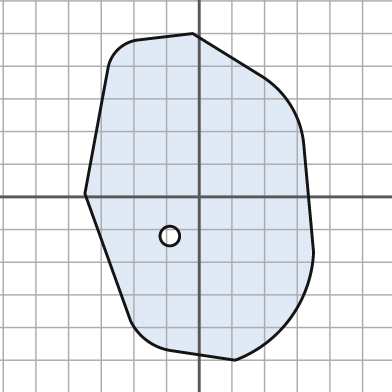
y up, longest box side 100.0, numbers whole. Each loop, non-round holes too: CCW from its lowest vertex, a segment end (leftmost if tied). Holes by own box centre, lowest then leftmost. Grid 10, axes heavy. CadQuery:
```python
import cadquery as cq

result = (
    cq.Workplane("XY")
    .moveTo(11.0, -50.0)
    .threePointArc((28.0, -37.0), (35.0, -17.0))
    .lineTo(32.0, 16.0)
    .threePointArc((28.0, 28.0), (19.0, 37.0))
    .lineTo(-2.0, 50.0)
    .lineTo(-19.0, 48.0)
    .threePointArc((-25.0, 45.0), (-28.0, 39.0))
    .lineTo(-35.0, 1.0)
    .lineTo(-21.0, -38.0)
    .threePointArc((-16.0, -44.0), (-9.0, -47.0))
    .close()
    .moveTo(-9.0, -12.0)
    .circle(3.0)
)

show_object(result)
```